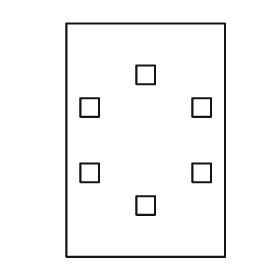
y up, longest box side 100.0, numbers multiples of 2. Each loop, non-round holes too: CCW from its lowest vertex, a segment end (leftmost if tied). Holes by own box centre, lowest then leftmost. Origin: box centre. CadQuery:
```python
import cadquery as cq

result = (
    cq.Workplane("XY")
    .moveTo(-34.0, -50.0)
    .lineTo(34.0, -50.0)
    .lineTo(34.0, 50.0)
    .lineTo(-34.0, 50.0)
    .close()
    .moveTo(-4.0, -32.0)
    .lineTo(4.0, -32.0)
    .lineTo(4.0, -24.0)
    .lineTo(-4.0, -24.0)
    .close()
    .moveTo(-28.0, -18.0)
    .lineTo(-20.0, -18.0)
    .lineTo(-20.0, -10.0)
    .lineTo(-28.0, -10.0)
    .close()
    .moveTo(20.0, -18.0)
    .lineTo(28.0, -18.0)
    .lineTo(28.0, -10.0)
    .lineTo(20.0, -10.0)
    .close()
    .moveTo(-28.0, 10.0)
    .lineTo(-20.0, 10.0)
    .lineTo(-20.0, 18.0)
    .lineTo(-28.0, 18.0)
    .close()
    .moveTo(20.0, 10.0)
    .lineTo(28.0, 10.0)
    .lineTo(28.0, 18.0)
    .lineTo(20.0, 18.0)
    .close()
    .moveTo(-4.0, 24.0)
    .lineTo(4.0, 24.0)
    .lineTo(4.0, 32.0)
    .lineTo(-4.0, 32.0)
    .close()
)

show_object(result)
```